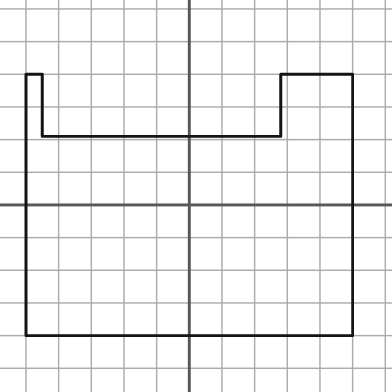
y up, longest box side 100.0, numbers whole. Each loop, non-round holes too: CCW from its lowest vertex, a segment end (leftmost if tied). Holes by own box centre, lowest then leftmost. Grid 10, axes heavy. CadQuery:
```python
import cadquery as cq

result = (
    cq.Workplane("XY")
    .moveTo(-50.0, -40.0)
    .lineTo(50.0, -40.0)
    .lineTo(50.0, 40.0)
    .lineTo(28.0, 40.0)
    .lineTo(28.0, 21.0)
    .lineTo(-45.0, 21.0)
    .lineTo(-45.0, 40.0)
    .lineTo(-50.0, 40.0)
    .close()
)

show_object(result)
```